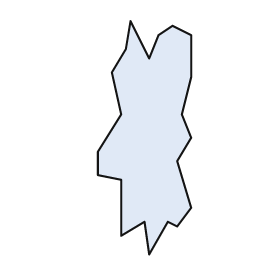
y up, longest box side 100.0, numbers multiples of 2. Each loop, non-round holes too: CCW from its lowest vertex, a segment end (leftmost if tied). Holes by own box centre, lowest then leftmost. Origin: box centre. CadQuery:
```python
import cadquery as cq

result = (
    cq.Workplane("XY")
    .moveTo(2.0, -50.0)
    .lineTo(10.0, -36.0)
    .lineTo(14.0, -38.0)
    .lineTo(20.0, -30.0)
    .lineTo(14.0, -10.0)
    .lineTo(20.0, 0.0)
    .lineTo(16.0, 10.0)
    .lineTo(20.0, 26.0)
    .lineTo(20.0, 44.0)
    .lineTo(12.0, 48.0)
    .lineTo(6.0, 44.0)
    .lineTo(2.0, 34.0)
    .lineTo(-6.0, 50.0)
    .lineTo(-8.0, 38.0)
    .lineTo(-14.0, 28.0)
    .lineTo(-10.0, 10.0)
    .lineTo(-20.0, -6.0)
    .lineTo(-20.0, -16.0)
    .lineTo(-10.0, -18.0)
    .lineTo(-10.0, -42.0)
    .lineTo(0.0, -36.0)
    .close()
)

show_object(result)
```